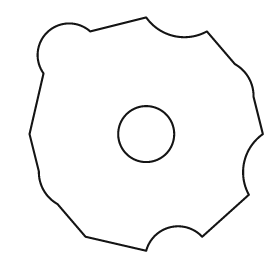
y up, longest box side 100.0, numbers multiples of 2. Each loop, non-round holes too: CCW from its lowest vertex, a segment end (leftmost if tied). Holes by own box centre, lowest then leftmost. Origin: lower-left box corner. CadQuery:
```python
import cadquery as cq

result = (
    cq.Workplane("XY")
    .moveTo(50.0, 0.0)
    .threePointArc((60.0, 10.0), (74.0, 6.0))
    .lineTo(94.0, 24.0)
    .threePointArc((92.0, 38.0), (100.0, 50.0))
    .lineTo(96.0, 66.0)
    .threePointArc((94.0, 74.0), (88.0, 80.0))
    .lineTo(76.0, 94.0)
    .threePointArc((62.0, 92.0), (50.0, 100.0))
    .lineTo(26.0, 94.0)
    .threePointArc((8.0, 94.0), (6.0, 76.0))
    .lineTo(0.0, 50.0)
    .lineTo(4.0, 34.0)
    .threePointArc((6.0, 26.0), (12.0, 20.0))
    .lineTo(24.0, 6.0)
    .close()
    .moveTo(50.0, 50.0)
    .circle(12.0)
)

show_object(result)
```